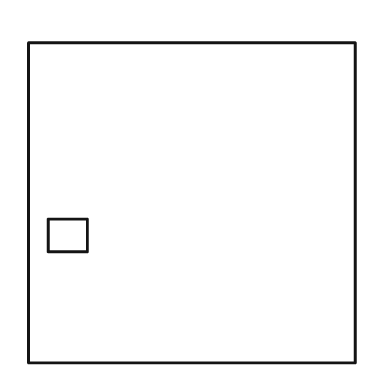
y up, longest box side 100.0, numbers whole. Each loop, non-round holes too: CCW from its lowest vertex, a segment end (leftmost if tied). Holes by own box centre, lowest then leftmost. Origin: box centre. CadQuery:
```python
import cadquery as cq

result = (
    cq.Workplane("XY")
    .moveTo(-50.0, -49.0)
    .lineTo(50.0, -49.0)
    .lineTo(50.0, 49.0)
    .lineTo(-50.0, 49.0)
    .close()
    .moveTo(-44.0, -15.0)
    .lineTo(-32.0, -15.0)
    .lineTo(-32.0, -5.0)
    .lineTo(-44.0, -5.0)
    .close()
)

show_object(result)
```